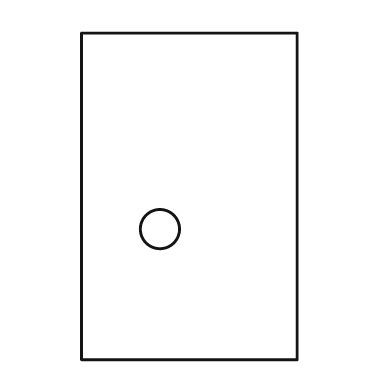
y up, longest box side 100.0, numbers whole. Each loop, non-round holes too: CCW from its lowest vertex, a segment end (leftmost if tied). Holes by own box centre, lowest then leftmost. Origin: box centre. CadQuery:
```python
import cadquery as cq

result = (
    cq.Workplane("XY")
    .moveTo(-33.0, -50.0)
    .lineTo(33.0, -50.0)
    .lineTo(33.0, 50.0)
    .lineTo(-33.0, 50.0)
    .close()
    .moveTo(-9.0, -10.0)
    .circle(6.0)
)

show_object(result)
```